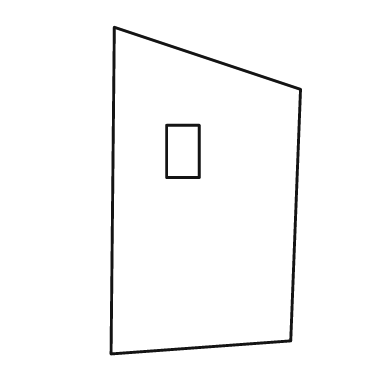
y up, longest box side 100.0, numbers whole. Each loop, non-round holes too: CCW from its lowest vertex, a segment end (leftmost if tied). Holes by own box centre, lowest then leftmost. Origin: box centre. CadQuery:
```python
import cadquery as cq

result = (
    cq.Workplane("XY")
    .moveTo(-29.0, -50.0)
    .lineTo(26.0, -46.0)
    .lineTo(29.0, 31.0)
    .lineTo(-28.0, 50.0)
    .close()
    .moveTo(-12.0, 4.0)
    .lineTo(-2.0, 4.0)
    .lineTo(-2.0, 20.0)
    .lineTo(-12.0, 20.0)
    .close()
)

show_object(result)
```